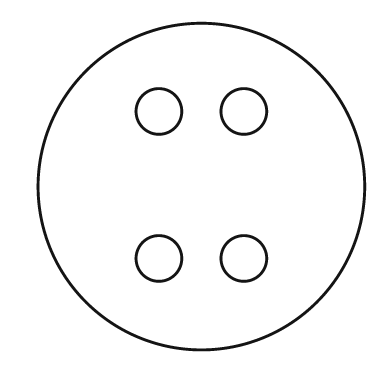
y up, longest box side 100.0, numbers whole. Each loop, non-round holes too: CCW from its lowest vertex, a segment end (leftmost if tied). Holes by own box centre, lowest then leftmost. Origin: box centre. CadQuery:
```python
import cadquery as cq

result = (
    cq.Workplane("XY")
    .moveTo(0.0, 0.0)
    .circle(50.0)
    .moveTo(-13.0, -22.0)
    .circle(7.0)
    .moveTo(13.0, -22.0)
    .circle(7.0)
    .moveTo(-13.0, 23.0)
    .circle(7.0)
    .moveTo(13.0, 23.0)
    .circle(7.0)
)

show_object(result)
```